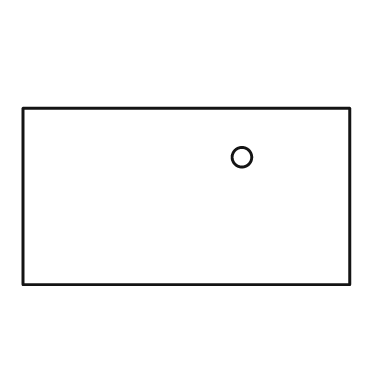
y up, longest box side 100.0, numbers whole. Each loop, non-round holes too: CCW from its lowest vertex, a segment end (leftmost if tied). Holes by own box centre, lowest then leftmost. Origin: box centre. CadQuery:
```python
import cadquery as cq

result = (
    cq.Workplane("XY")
    .moveTo(-50.0, -27.0)
    .lineTo(50.0, -27.0)
    .lineTo(50.0, 27.0)
    .lineTo(-50.0, 27.0)
    .close()
    .moveTo(17.0, 12.0)
    .circle(3.0)
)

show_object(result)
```